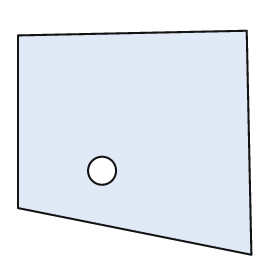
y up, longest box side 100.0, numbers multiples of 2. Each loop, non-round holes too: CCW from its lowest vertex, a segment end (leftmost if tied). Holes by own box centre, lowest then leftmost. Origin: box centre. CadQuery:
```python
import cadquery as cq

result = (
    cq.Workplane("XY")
    .moveTo(50.0, -48.0)
    .lineTo(48.0, 48.0)
    .lineTo(-50.0, 46.0)
    .lineTo(-50.0, -28.0)
    .close()
    .moveTo(-14.0, -12.0)
    .circle(6.0)
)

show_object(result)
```